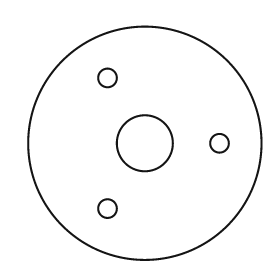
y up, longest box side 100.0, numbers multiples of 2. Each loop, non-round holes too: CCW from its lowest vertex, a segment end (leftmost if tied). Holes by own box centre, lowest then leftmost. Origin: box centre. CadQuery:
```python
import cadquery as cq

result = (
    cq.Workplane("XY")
    .moveTo(0.0, 0.0)
    .circle(50.0)
    .moveTo(-16.0, -28.0)
    .circle(4.0)
    .moveTo(0.0, 0.0)
    .circle(12.0)
    .moveTo(32.0, 0.0)
    .circle(4.0)
    .moveTo(-16.0, 28.0)
    .circle(4.0)
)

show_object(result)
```